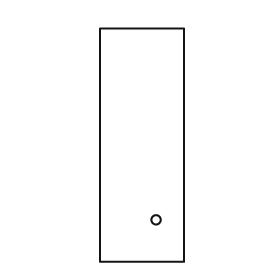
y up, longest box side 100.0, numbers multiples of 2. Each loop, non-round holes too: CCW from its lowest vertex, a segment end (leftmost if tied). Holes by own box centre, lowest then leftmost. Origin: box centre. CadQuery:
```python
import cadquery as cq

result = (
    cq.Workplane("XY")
    .moveTo(-18.0, -50.0)
    .lineTo(18.0, -50.0)
    .lineTo(18.0, 50.0)
    .lineTo(-18.0, 50.0)
    .close()
    .moveTo(6.0, -32.0)
    .circle(2.0)
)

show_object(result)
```